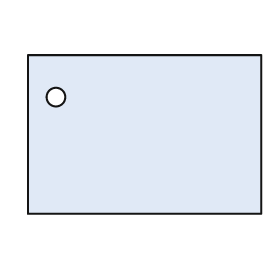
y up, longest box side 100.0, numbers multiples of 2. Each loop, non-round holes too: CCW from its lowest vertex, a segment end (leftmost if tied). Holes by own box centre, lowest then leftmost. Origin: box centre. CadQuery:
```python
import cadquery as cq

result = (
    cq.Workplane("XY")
    .moveTo(-50.0, -34.0)
    .lineTo(50.0, -34.0)
    .lineTo(50.0, 34.0)
    .lineTo(-50.0, 34.0)
    .close()
    .moveTo(-38.0, 16.0)
    .circle(4.0)
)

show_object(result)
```